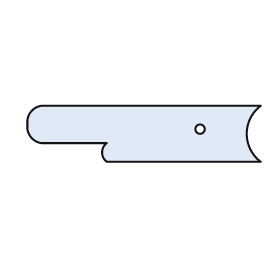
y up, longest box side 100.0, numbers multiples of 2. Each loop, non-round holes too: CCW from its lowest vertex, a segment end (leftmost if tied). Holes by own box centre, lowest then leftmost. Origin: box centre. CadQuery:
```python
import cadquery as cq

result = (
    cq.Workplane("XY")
    .moveTo(-16.0, -12.0)
    .lineTo(50.0, -12.0)
    .threePointArc((44.0, 0.0), (50.0, 12.0))
    .lineTo(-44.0, 12.0)
    .threePointArc((-48.0, 10.0), (-50.0, 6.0))
    .lineTo(-50.0, 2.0)
    .threePointArc((-48.0, -2.0), (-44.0, -4.0))
    .lineTo(-16.0, -4.0)
    .threePointArc((-18.0, -8.0), (-16.0, -12.0))
    .close()
    .moveTo(24.0, 2.0)
    .circle(2.0)
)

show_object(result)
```